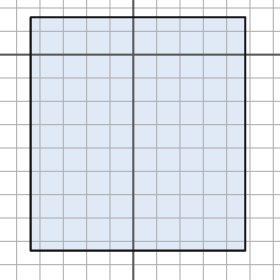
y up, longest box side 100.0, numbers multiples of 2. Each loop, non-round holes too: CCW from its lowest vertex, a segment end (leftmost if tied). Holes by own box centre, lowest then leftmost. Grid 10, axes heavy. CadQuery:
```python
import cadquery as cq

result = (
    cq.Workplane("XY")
    .moveTo(-44.0, -84.0)
    .lineTo(48.0, -84.0)
    .lineTo(48.0, 16.0)
    .lineTo(-44.0, 16.0)
    .close()
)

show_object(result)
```